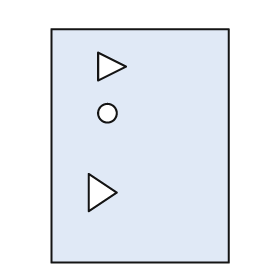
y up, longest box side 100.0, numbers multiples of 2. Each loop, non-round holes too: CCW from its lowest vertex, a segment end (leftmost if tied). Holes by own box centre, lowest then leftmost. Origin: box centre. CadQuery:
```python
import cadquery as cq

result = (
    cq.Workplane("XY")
    .moveTo(-38.0, -50.0)
    .lineTo(38.0, -50.0)
    .lineTo(38.0, 50.0)
    .lineTo(-38.0, 50.0)
    .close()
    .moveTo(-22.0, -28.0)
    .lineTo(-10.0, -20.0)
    .lineTo(-22.0, -12.0)
    .close()
    .moveTo(-14.0, 14.0)
    .circle(4.0)
    .moveTo(-18.0, 28.0)
    .lineTo(-6.0, 34.0)
    .lineTo(-18.0, 40.0)
    .close()
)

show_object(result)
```